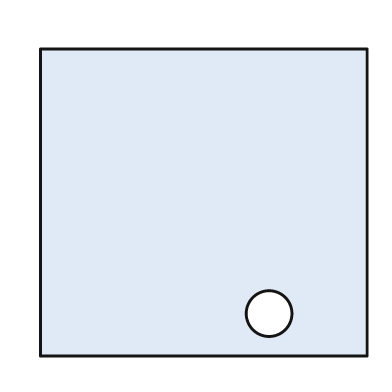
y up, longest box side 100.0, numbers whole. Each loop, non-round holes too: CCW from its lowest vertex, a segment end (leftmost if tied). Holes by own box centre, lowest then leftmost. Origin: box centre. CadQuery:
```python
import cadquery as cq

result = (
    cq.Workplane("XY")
    .moveTo(-50.0, -47.0)
    .lineTo(50.0, -47.0)
    .lineTo(50.0, 47.0)
    .lineTo(-50.0, 47.0)
    .close()
    .moveTo(20.0, -34.0)
    .circle(7.0)
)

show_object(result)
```